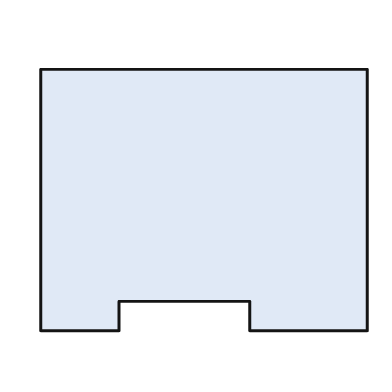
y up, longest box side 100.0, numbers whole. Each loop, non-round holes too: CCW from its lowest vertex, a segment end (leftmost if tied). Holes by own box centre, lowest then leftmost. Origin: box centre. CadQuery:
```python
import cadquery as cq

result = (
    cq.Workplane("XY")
    .moveTo(-50.0, -40.0)
    .lineTo(-26.0, -40.0)
    .lineTo(-26.0, -31.0)
    .lineTo(14.0, -31.0)
    .lineTo(14.0, -40.0)
    .lineTo(50.0, -40.0)
    .lineTo(50.0, 40.0)
    .lineTo(-50.0, 40.0)
    .close()
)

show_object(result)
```